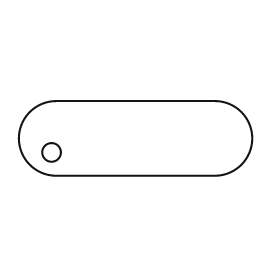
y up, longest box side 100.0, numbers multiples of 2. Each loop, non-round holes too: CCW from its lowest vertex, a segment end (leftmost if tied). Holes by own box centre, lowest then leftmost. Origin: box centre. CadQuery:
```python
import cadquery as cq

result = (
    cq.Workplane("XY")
    .moveTo(-34.0, -16.0)
    .lineTo(34.0, -16.0)
    .threePointArc((50.0, 0.0), (34.0, 16.0))
    .lineTo(-34.0, 16.0)
    .threePointArc((-50.0, 0.0), (-34.0, -16.0))
    .close()
    .moveTo(-36.0, -6.0)
    .circle(4.0)
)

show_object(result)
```